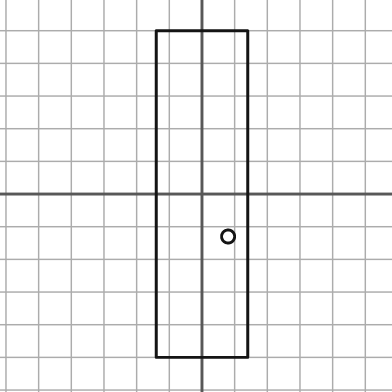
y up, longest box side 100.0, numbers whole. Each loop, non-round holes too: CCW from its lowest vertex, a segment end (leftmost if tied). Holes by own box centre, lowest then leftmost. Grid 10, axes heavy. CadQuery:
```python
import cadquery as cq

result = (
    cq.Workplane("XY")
    .moveTo(-14.0, -50.0)
    .lineTo(14.0, -50.0)
    .lineTo(14.0, 50.0)
    .lineTo(-14.0, 50.0)
    .close()
    .moveTo(8.0, -13.0)
    .circle(2.0)
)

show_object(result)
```